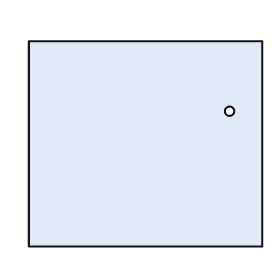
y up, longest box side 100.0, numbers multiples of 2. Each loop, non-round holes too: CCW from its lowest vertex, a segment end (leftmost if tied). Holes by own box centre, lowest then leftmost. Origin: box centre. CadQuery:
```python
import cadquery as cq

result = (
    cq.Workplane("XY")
    .moveTo(-50.0, -44.0)
    .lineTo(50.0, -44.0)
    .lineTo(50.0, 44.0)
    .lineTo(-50.0, 44.0)
    .close()
    .moveTo(36.0, 14.0)
    .circle(2.0)
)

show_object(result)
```